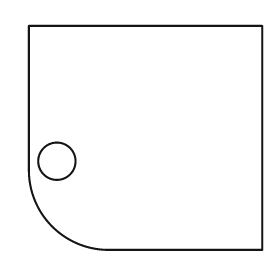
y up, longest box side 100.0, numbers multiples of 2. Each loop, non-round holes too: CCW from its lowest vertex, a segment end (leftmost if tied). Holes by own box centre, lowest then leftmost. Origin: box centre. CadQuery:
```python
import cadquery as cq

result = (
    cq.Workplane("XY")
    .moveTo(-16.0, -48.0)
    .lineTo(50.0, -48.0)
    .lineTo(50.0, 48.0)
    .lineTo(-50.0, 48.0)
    .lineTo(-50.0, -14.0)
    .threePointArc((-40.0, -38.0), (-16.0, -48.0))
    .close()
    .moveTo(-38.0, -10.0)
    .circle(8.0)
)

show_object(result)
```